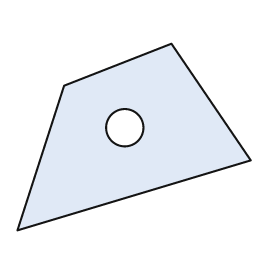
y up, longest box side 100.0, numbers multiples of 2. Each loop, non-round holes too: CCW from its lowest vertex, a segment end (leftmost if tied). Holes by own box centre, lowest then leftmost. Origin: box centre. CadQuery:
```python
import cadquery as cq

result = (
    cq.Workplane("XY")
    .moveTo(-50.0, -40.0)
    .lineTo(50.0, -10.0)
    .lineTo(16.0, 40.0)
    .lineTo(-30.0, 22.0)
    .close()
    .moveTo(-4.0, 4.0)
    .circle(8.0)
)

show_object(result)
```